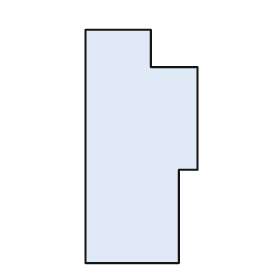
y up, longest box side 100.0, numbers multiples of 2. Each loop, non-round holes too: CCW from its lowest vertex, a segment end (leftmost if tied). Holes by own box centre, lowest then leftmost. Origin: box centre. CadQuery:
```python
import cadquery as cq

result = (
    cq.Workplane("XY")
    .moveTo(-24.0, -50.0)
    .lineTo(16.0, -50.0)
    .lineTo(16.0, -10.0)
    .lineTo(24.0, -10.0)
    .lineTo(24.0, 34.0)
    .lineTo(4.0, 34.0)
    .lineTo(4.0, 50.0)
    .lineTo(-24.0, 50.0)
    .close()
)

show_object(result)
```